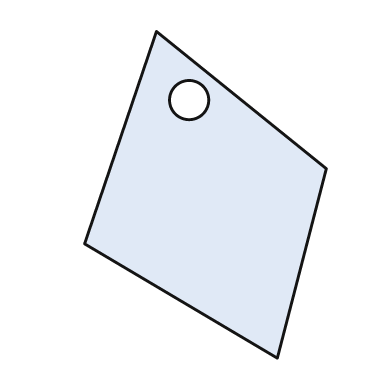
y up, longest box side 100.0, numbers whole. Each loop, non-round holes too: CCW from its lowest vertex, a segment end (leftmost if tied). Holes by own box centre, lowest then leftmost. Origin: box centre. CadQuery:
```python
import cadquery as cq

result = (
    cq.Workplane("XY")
    .moveTo(22.0, -50.0)
    .lineTo(37.0, 8.0)
    .lineTo(-15.0, 50.0)
    .lineTo(-37.0, -15.0)
    .close()
    .moveTo(-5.0, 29.0)
    .circle(6.0)
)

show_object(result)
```